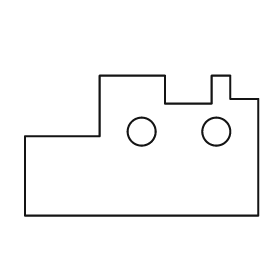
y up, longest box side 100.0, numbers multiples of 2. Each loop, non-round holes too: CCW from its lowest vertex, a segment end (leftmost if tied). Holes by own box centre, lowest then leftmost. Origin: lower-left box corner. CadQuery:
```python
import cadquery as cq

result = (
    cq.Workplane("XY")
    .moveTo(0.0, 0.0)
    .lineTo(100.0, 0.0)
    .lineTo(100.0, 50.0)
    .lineTo(88.0, 50.0)
    .lineTo(88.0, 60.0)
    .lineTo(80.0, 60.0)
    .lineTo(80.0, 48.0)
    .lineTo(60.0, 48.0)
    .lineTo(60.0, 60.0)
    .lineTo(32.0, 60.0)
    .lineTo(32.0, 34.0)
    .lineTo(0.0, 34.0)
    .close()
    .moveTo(50.0, 36.0)
    .circle(6.0)
    .moveTo(82.0, 36.0)
    .circle(6.0)
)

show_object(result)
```